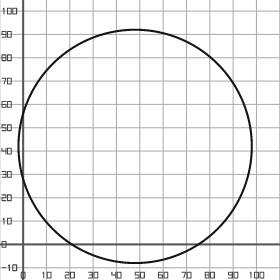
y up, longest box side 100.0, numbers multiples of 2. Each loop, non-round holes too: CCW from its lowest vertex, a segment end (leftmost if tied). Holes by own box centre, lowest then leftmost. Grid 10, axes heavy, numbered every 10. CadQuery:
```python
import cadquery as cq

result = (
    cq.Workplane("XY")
    .moveTo(48.0, 42.0)
    .circle(50.0)
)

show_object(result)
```